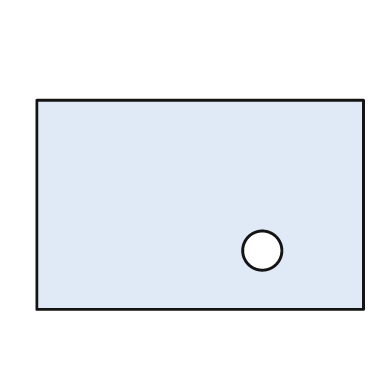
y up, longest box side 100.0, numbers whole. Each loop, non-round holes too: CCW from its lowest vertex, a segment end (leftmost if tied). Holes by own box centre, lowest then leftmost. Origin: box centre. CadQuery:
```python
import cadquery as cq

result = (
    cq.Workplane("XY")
    .moveTo(-50.0, -32.0)
    .lineTo(50.0, -32.0)
    .lineTo(50.0, 32.0)
    .lineTo(-50.0, 32.0)
    .close()
    .moveTo(19.0, -14.0)
    .circle(6.0)
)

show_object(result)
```